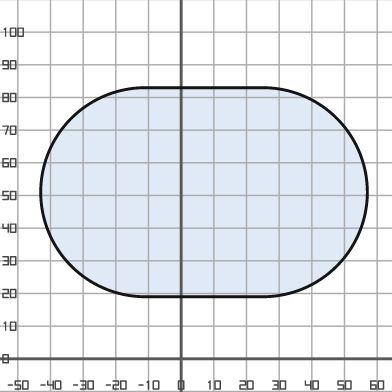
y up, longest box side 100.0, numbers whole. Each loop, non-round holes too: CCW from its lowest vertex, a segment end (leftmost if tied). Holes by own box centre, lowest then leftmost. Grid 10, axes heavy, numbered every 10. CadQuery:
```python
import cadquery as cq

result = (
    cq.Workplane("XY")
    .moveTo(-11.0, 19.0)
    .lineTo(25.0, 19.0)
    .threePointArc((57.0, 51.0), (25.0, 83.0))
    .lineTo(-11.0, 83.0)
    .threePointArc((-43.0, 51.0), (-11.0, 19.0))
    .close()
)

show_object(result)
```